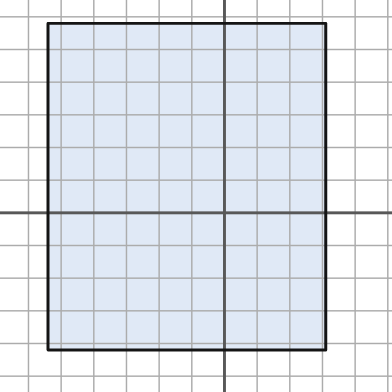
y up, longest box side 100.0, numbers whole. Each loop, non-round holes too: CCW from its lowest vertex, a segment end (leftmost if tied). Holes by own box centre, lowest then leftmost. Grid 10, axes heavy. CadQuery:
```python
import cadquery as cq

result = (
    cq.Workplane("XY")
    .moveTo(-54.0, -42.0)
    .lineTo(31.0, -42.0)
    .lineTo(31.0, 58.0)
    .lineTo(-54.0, 58.0)
    .close()
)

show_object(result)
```